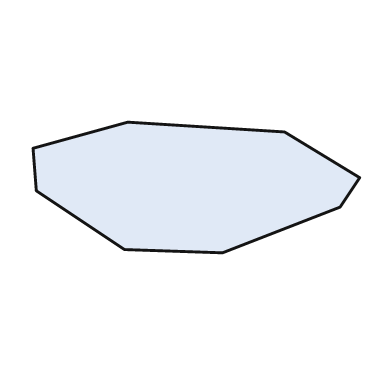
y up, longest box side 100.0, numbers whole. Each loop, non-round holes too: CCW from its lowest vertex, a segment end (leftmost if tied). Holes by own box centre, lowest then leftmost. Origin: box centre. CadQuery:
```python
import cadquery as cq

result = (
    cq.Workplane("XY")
    .moveTo(8.0, -20.0)
    .lineTo(44.0, -6.0)
    .lineTo(50.0, 3.0)
    .lineTo(27.0, 17.0)
    .lineTo(-21.0, 20.0)
    .lineTo(-50.0, 12.0)
    .lineTo(-49.0, -1.0)
    .lineTo(-22.0, -19.0)
    .close()
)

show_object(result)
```